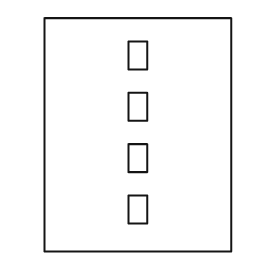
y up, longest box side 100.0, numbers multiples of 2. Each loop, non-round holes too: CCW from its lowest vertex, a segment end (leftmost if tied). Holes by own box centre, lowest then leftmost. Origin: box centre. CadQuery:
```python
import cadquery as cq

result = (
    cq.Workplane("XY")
    .moveTo(-40.0, -50.0)
    .lineTo(40.0, -50.0)
    .lineTo(40.0, 50.0)
    .lineTo(-40.0, 50.0)
    .close()
    .moveTo(-4.0, -38.0)
    .lineTo(4.0, -38.0)
    .lineTo(4.0, -26.0)
    .lineTo(-4.0, -26.0)
    .close()
    .moveTo(-4.0, -16.0)
    .lineTo(4.0, -16.0)
    .lineTo(4.0, -4.0)
    .lineTo(-4.0, -4.0)
    .close()
    .moveTo(-4.0, 6.0)
    .lineTo(4.0, 6.0)
    .lineTo(4.0, 18.0)
    .lineTo(-4.0, 18.0)
    .close()
    .moveTo(-4.0, 28.0)
    .lineTo(4.0, 28.0)
    .lineTo(4.0, 40.0)
    .lineTo(-4.0, 40.0)
    .close()
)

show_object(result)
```